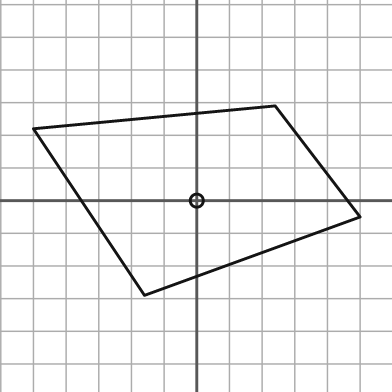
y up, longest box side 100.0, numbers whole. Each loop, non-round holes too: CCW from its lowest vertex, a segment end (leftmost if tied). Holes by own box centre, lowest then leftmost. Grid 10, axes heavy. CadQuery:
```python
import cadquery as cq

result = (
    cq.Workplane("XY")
    .moveTo(-16.0, -29.0)
    .lineTo(50.0, -5.0)
    .lineTo(24.0, 29.0)
    .lineTo(-50.0, 22.0)
    .close()
    .moveTo(0.0, 0.0)
    .circle(2.0)
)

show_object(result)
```